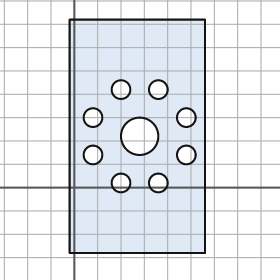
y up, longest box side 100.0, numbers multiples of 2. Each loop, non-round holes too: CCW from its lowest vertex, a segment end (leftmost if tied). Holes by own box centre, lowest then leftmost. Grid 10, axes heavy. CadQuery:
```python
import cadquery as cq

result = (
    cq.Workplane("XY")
    .moveTo(-2.0, -28.0)
    .lineTo(56.0, -28.0)
    .lineTo(56.0, 72.0)
    .lineTo(-2.0, 72.0)
    .close()
    .moveTo(20.0, 2.0)
    .circle(4.0)
    .moveTo(36.0, 2.0)
    .circle(4.0)
    .moveTo(8.0, 14.0)
    .circle(4.0)
    .moveTo(48.0, 14.0)
    .circle(4.0)
    .moveTo(28.0, 22.0)
    .circle(8.0)
    .moveTo(8.0, 30.0)
    .circle(4.0)
    .moveTo(48.0, 30.0)
    .circle(4.0)
    .moveTo(20.0, 42.0)
    .circle(4.0)
    .moveTo(36.0, 42.0)
    .circle(4.0)
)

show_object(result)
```